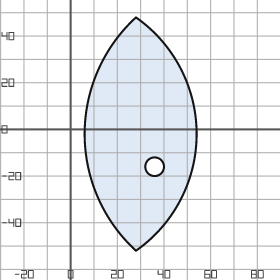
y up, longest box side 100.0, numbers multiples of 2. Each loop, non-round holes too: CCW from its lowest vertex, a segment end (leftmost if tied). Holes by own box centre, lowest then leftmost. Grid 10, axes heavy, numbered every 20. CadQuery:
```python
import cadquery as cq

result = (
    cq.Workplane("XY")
    .moveTo(28.0, -52.0)
    .threePointArc((54.0, -2.0), (28.0, 48.0))
    .threePointArc((6.0, -2.0), (28.0, -52.0))
    .close()
    .moveTo(36.0, -16.0)
    .circle(4.0)
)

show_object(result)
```